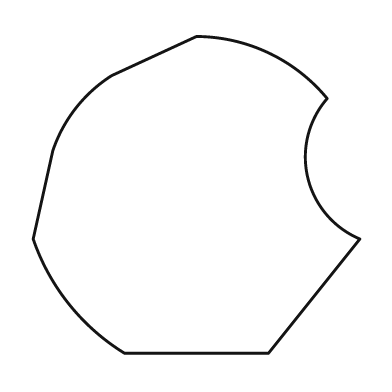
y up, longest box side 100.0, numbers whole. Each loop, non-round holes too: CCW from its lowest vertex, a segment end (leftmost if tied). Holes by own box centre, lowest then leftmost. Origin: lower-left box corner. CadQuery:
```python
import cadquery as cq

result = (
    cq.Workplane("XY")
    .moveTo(28.0, 0.0)
    .lineTo(72.0, 0.0)
    .lineTo(100.0, 35.0)
    .threePointArc((84.0, 54.0), (90.0, 78.0))
    .threePointArc((72.0, 92.0), (50.0, 97.0))
    .lineTo(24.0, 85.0)
    .threePointArc((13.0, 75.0), (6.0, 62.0))
    .lineTo(0.0, 35.0)
    .threePointArc((11.0, 15.0), (28.0, 0.0))
    .close()
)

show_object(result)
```